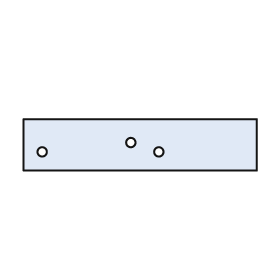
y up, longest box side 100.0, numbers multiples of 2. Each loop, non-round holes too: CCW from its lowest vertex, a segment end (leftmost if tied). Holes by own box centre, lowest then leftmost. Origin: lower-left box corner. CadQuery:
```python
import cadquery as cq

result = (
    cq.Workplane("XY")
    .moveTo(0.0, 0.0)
    .lineTo(100.0, 0.0)
    .lineTo(100.0, 22.0)
    .lineTo(0.0, 22.0)
    .close()
    .moveTo(8.0, 8.0)
    .circle(2.0)
    .moveTo(58.0, 8.0)
    .circle(2.0)
    .moveTo(46.0, 12.0)
    .circle(2.0)
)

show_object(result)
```